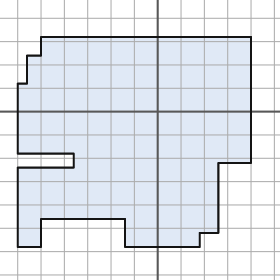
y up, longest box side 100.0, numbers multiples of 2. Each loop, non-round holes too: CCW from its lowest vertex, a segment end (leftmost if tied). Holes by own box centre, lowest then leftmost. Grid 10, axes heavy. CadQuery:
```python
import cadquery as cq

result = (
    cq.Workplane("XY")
    .moveTo(-60.0, -58.0)
    .lineTo(-50.0, -58.0)
    .lineTo(-50.0, -46.0)
    .lineTo(-14.0, -46.0)
    .lineTo(-14.0, -58.0)
    .lineTo(18.0, -58.0)
    .lineTo(18.0, -52.0)
    .lineTo(26.0, -52.0)
    .lineTo(26.0, -22.0)
    .lineTo(40.0, -22.0)
    .lineTo(40.0, 32.0)
    .lineTo(-50.0, 32.0)
    .lineTo(-50.0, 24.0)
    .lineTo(-56.0, 24.0)
    .lineTo(-56.0, 12.0)
    .lineTo(-60.0, 12.0)
    .lineTo(-60.0, -18.0)
    .lineTo(-36.0, -18.0)
    .lineTo(-36.0, -24.0)
    .lineTo(-60.0, -24.0)
    .close()
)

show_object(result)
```